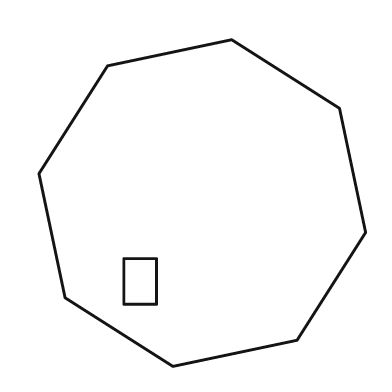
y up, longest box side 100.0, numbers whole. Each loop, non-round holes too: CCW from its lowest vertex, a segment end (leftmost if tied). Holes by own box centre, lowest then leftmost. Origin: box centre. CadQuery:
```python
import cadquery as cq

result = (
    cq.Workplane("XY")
    .moveTo(-9.0, -50.0)
    .lineTo(29.0, -42.0)
    .lineTo(50.0, -9.0)
    .lineTo(42.0, 29.0)
    .lineTo(9.0, 50.0)
    .lineTo(-29.0, 42.0)
    .lineTo(-50.0, 9.0)
    .lineTo(-42.0, -29.0)
    .close()
    .moveTo(-24.0, -31.0)
    .lineTo(-14.0, -31.0)
    .lineTo(-14.0, -17.0)
    .lineTo(-24.0, -17.0)
    .close()
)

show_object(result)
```